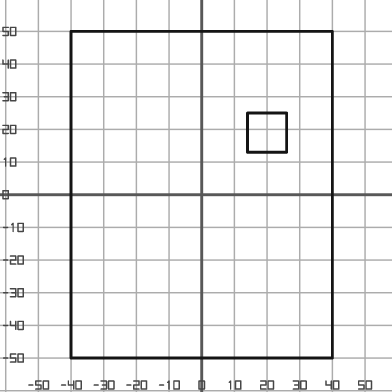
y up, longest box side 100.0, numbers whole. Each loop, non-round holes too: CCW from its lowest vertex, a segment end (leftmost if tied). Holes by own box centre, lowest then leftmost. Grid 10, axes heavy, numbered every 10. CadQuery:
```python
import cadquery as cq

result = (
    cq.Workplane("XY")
    .moveTo(-40.0, -50.0)
    .lineTo(40.0, -50.0)
    .lineTo(40.0, 50.0)
    .lineTo(-40.0, 50.0)
    .close()
    .moveTo(14.0, 13.0)
    .lineTo(26.0, 13.0)
    .lineTo(26.0, 25.0)
    .lineTo(14.0, 25.0)
    .close()
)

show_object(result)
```